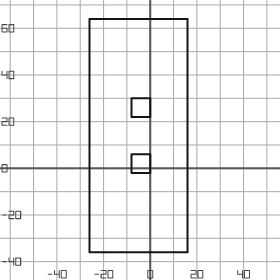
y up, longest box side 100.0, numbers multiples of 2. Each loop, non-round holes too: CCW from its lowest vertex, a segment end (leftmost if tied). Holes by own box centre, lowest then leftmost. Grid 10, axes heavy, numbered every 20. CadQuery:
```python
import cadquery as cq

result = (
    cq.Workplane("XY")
    .moveTo(-26.0, -36.0)
    .lineTo(16.0, -36.0)
    .lineTo(16.0, 64.0)
    .lineTo(-26.0, 64.0)
    .close()
    .moveTo(-8.0, -2.0)
    .lineTo(0.0, -2.0)
    .lineTo(0.0, 6.0)
    .lineTo(-8.0, 6.0)
    .close()
    .moveTo(-8.0, 22.0)
    .lineTo(0.0, 22.0)
    .lineTo(0.0, 30.0)
    .lineTo(-8.0, 30.0)
    .close()
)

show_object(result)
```